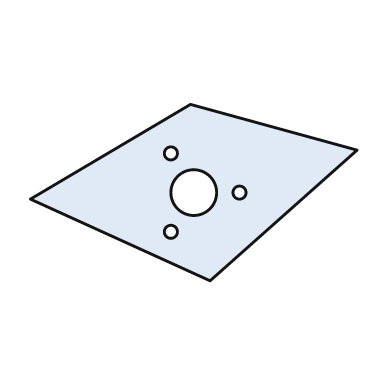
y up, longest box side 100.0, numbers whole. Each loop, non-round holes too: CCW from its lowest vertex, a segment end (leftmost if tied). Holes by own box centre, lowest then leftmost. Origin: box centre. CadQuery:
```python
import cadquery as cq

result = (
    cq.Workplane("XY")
    .moveTo(5.0, -27.0)
    .lineTo(50.0, 13.0)
    .lineTo(-1.0, 27.0)
    .lineTo(-50.0, -2.0)
    .close()
    .moveTo(-7.0, -12.0)
    .circle(2.0)
    .moveTo(0.0, 0.0)
    .circle(7.0)
    .moveTo(14.0, 0.0)
    .circle(2.0)
    .moveTo(-7.0, 12.0)
    .circle(2.0)
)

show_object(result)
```